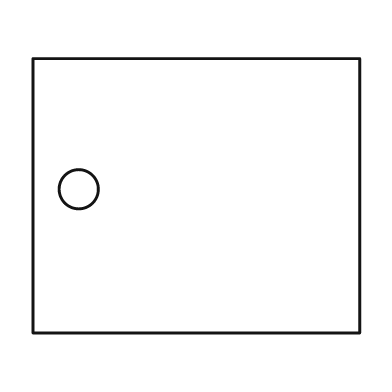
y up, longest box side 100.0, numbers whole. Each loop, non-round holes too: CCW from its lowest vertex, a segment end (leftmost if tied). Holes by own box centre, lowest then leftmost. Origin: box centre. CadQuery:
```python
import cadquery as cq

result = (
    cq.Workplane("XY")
    .moveTo(-50.0, -42.0)
    .lineTo(50.0, -42.0)
    .lineTo(50.0, 42.0)
    .lineTo(-50.0, 42.0)
    .close()
    .moveTo(-36.0, 2.0)
    .circle(6.0)
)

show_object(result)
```